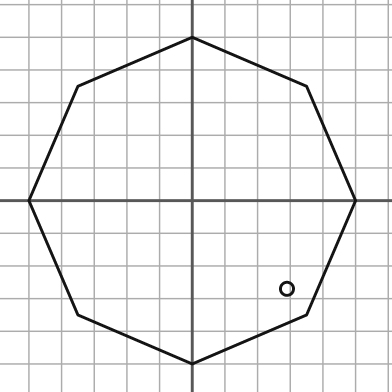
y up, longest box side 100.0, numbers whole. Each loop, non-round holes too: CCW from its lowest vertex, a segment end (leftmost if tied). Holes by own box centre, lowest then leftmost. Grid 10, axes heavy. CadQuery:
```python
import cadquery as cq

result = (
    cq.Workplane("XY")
    .moveTo(0.0, -50.0)
    .lineTo(35.0, -35.0)
    .lineTo(50.0, 0.0)
    .lineTo(35.0, 35.0)
    .lineTo(0.0, 50.0)
    .lineTo(-35.0, 35.0)
    .lineTo(-50.0, 0.0)
    .lineTo(-35.0, -35.0)
    .close()
    .moveTo(29.0, -27.0)
    .circle(2.0)
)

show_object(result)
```